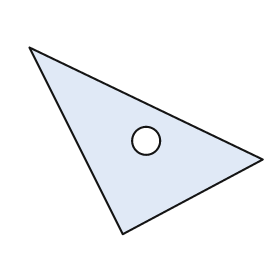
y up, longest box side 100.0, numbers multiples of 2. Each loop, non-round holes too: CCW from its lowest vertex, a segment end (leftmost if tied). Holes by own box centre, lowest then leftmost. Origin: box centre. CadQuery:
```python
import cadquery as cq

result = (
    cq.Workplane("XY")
    .moveTo(-10.0, -40.0)
    .lineTo(50.0, -8.0)
    .lineTo(-50.0, 40.0)
    .close()
    .moveTo(0.0, 0.0)
    .circle(6.0)
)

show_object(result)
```